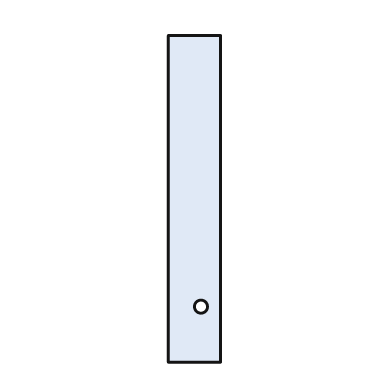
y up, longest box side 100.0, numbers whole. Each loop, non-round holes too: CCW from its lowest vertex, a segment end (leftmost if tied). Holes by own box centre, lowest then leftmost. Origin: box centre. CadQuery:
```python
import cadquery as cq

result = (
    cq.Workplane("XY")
    .moveTo(-8.0, -50.0)
    .lineTo(8.0, -50.0)
    .lineTo(8.0, 50.0)
    .lineTo(-8.0, 50.0)
    .close()
    .moveTo(2.0, -33.0)
    .circle(2.0)
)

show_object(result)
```